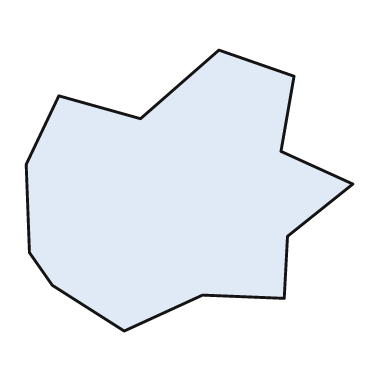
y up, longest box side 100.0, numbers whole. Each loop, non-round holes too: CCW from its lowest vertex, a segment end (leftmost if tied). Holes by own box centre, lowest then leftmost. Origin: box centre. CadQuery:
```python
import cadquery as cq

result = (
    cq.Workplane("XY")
    .moveTo(-20.0, -43.0)
    .lineTo(4.0, -32.0)
    .lineTo(29.0, -33.0)
    .lineTo(30.0, -14.0)
    .lineTo(50.0, 2.0)
    .lineTo(28.0, 12.0)
    .lineTo(32.0, 35.0)
    .lineTo(9.0, 43.0)
    .lineTo(-15.0, 22.0)
    .lineTo(-40.0, 29.0)
    .lineTo(-50.0, 8.0)
    .lineTo(-49.0, -19.0)
    .lineTo(-42.0, -29.0)
    .close()
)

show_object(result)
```